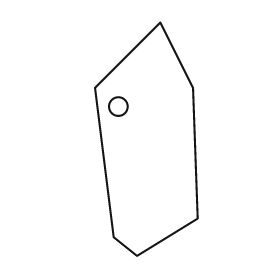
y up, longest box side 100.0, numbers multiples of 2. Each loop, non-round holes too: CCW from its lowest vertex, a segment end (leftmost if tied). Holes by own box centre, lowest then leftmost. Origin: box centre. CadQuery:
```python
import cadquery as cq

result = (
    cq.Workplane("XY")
    .moveTo(-4.0, -50.0)
    .lineTo(22.0, -34.0)
    .lineTo(20.0, 22.0)
    .lineTo(6.0, 50.0)
    .lineTo(-22.0, 22.0)
    .lineTo(-14.0, -42.0)
    .close()
    .moveTo(-12.0, 14.0)
    .circle(4.0)
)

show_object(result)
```